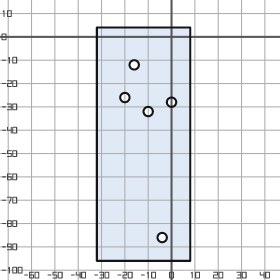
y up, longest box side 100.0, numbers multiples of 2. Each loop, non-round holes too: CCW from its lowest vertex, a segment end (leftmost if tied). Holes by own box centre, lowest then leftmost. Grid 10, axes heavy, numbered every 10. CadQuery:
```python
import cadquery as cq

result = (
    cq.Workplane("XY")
    .moveTo(-32.0, -96.0)
    .lineTo(8.0, -96.0)
    .lineTo(8.0, 4.0)
    .lineTo(-32.0, 4.0)
    .close()
    .moveTo(-4.0, -86.0)
    .circle(2.0)
    .moveTo(-10.0, -32.0)
    .circle(2.0)
    .moveTo(0.0, -28.0)
    .circle(2.0)
    .moveTo(-20.0, -26.0)
    .circle(2.0)
    .moveTo(-16.0, -12.0)
    .circle(2.0)
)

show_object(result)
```